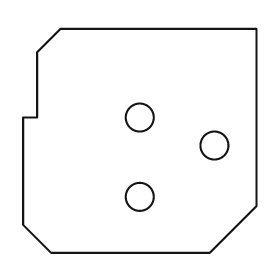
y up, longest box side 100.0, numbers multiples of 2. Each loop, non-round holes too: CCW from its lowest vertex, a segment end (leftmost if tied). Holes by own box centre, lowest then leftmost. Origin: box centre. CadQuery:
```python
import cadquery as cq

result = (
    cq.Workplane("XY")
    .moveTo(-38.0, -48.0)
    .lineTo(30.0, -48.0)
    .lineTo(50.0, -28.0)
    .lineTo(50.0, 48.0)
    .lineTo(-34.0, 48.0)
    .lineTo(-44.0, 38.0)
    .lineTo(-44.0, 10.0)
    .lineTo(-50.0, 10.0)
    .lineTo(-50.0, -36.0)
    .close()
    .moveTo(0.0, -24.0)
    .circle(6.0)
    .moveTo(32.0, -2.0)
    .circle(6.0)
    .moveTo(0.0, 10.0)
    .circle(6.0)
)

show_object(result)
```